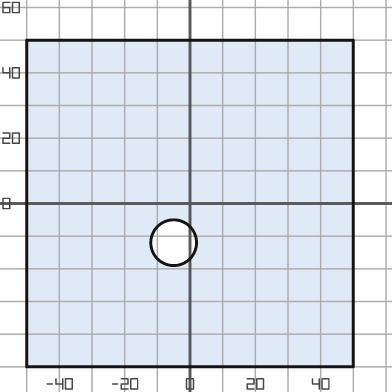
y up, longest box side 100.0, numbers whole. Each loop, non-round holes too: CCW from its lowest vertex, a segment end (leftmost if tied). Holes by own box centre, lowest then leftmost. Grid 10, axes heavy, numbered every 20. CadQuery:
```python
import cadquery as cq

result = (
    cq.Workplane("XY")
    .moveTo(-50.0, -50.0)
    .lineTo(50.0, -50.0)
    .lineTo(50.0, 50.0)
    .lineTo(-50.0, 50.0)
    .close()
    .moveTo(-5.0, -12.0)
    .circle(7.0)
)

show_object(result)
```